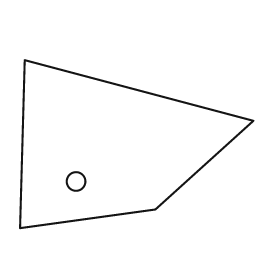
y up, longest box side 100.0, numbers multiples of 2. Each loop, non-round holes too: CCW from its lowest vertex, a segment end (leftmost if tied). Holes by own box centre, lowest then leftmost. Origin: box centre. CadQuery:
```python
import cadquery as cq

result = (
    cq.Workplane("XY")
    .moveTo(-50.0, -36.0)
    .lineTo(8.0, -28.0)
    .lineTo(50.0, 10.0)
    .lineTo(-48.0, 36.0)
    .close()
    .moveTo(-26.0, -16.0)
    .circle(4.0)
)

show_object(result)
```